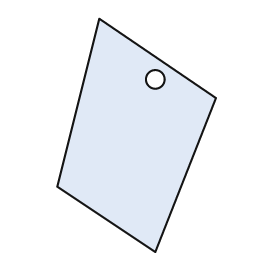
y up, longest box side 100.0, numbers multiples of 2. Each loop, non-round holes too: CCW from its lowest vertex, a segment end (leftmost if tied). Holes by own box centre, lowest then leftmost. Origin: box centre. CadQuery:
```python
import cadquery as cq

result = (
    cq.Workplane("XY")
    .moveTo(8.0, -50.0)
    .lineTo(34.0, 16.0)
    .lineTo(-16.0, 50.0)
    .lineTo(-34.0, -22.0)
    .close()
    .moveTo(8.0, 24.0)
    .circle(4.0)
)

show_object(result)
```